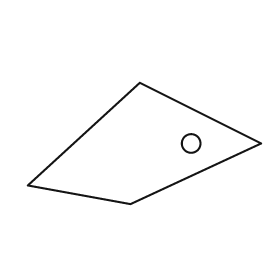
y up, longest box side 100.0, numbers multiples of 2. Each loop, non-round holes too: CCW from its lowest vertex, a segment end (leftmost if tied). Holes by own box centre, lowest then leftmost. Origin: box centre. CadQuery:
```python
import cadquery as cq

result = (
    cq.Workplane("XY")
    .moveTo(-6.0, -26.0)
    .lineTo(50.0, 0.0)
    .lineTo(-2.0, 26.0)
    .lineTo(-50.0, -18.0)
    .close()
    .moveTo(20.0, 0.0)
    .circle(4.0)
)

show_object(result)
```